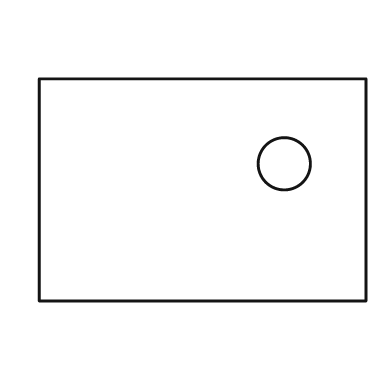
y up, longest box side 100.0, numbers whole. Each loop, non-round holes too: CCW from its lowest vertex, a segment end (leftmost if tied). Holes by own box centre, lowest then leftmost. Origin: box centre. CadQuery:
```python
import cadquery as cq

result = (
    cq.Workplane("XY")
    .moveTo(-50.0, -34.0)
    .lineTo(50.0, -34.0)
    .lineTo(50.0, 34.0)
    .lineTo(-50.0, 34.0)
    .close()
    .moveTo(25.0, 8.0)
    .circle(8.0)
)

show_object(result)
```